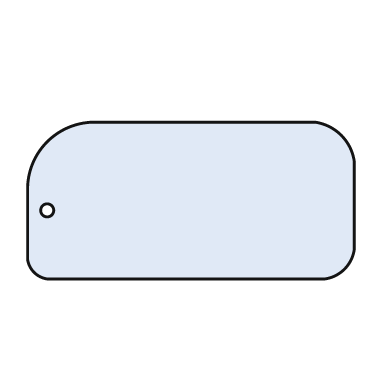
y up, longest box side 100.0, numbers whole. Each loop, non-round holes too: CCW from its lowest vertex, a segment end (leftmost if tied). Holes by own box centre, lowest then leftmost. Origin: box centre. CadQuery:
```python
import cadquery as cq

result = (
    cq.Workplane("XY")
    .moveTo(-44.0, -24.0)
    .lineTo(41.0, -24.0)
    .threePointArc((47.0, -21.0), (50.0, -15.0))
    .lineTo(50.0, 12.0)
    .threePointArc((46.0, 20.0), (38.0, 24.0))
    .lineTo(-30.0, 24.0)
    .threePointArc((-44.0, 18.0), (-50.0, 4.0))
    .lineTo(-50.0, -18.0)
    .threePointArc((-48.0, -22.0), (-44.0, -24.0))
    .close()
    .moveTo(-44.0, -3.0)
    .circle(2.0)
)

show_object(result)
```